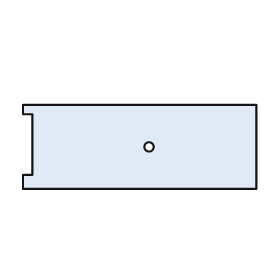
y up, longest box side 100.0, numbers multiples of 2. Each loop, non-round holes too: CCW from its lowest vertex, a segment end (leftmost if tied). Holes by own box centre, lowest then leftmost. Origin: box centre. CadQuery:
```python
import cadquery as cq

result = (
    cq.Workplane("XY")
    .moveTo(-50.0, -18.0)
    .lineTo(50.0, -18.0)
    .lineTo(50.0, 18.0)
    .lineTo(-50.0, 18.0)
    .lineTo(-50.0, 14.0)
    .lineTo(-46.0, 14.0)
    .lineTo(-46.0, -12.0)
    .lineTo(-50.0, -12.0)
    .close()
    .moveTo(4.0, 0.0)
    .circle(2.0)
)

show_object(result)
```